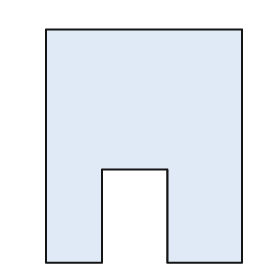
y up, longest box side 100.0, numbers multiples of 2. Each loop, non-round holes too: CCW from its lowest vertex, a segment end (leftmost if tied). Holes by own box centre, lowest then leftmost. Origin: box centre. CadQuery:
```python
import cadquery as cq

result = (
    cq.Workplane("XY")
    .moveTo(-42.0, -50.0)
    .lineTo(-18.0, -50.0)
    .lineTo(-18.0, -10.0)
    .lineTo(10.0, -10.0)
    .lineTo(10.0, -50.0)
    .lineTo(42.0, -50.0)
    .lineTo(42.0, 50.0)
    .lineTo(-42.0, 50.0)
    .close()
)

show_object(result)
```